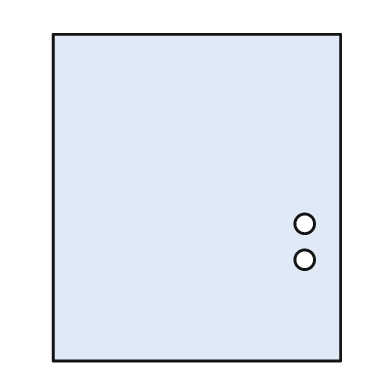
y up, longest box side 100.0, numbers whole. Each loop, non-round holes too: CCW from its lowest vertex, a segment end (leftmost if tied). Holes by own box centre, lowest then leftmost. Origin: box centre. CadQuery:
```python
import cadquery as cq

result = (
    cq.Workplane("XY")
    .moveTo(-44.0, -50.0)
    .lineTo(44.0, -50.0)
    .lineTo(44.0, 50.0)
    .lineTo(-44.0, 50.0)
    .close()
    .moveTo(33.0, -19.0)
    .circle(3.0)
    .moveTo(33.0, -8.0)
    .circle(3.0)
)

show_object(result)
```